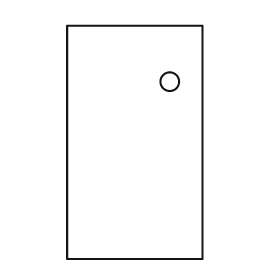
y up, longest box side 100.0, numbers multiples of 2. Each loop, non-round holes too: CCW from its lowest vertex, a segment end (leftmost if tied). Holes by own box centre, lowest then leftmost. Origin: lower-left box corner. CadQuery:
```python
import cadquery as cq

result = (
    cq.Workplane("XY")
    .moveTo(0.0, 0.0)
    .lineTo(58.0, 0.0)
    .lineTo(58.0, 100.0)
    .lineTo(0.0, 100.0)
    .close()
    .moveTo(44.0, 76.0)
    .circle(4.0)
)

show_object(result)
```